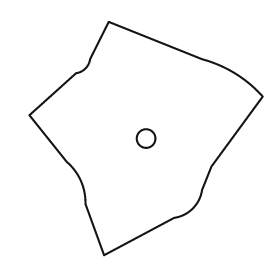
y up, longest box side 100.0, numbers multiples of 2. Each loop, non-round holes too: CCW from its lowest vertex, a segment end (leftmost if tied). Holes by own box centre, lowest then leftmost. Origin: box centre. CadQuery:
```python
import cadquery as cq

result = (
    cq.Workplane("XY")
    .moveTo(-18.0, -50.0)
    .lineTo(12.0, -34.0)
    .threePointArc((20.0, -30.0), (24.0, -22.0))
    .lineTo(28.0, -12.0)
    .lineTo(50.0, 18.0)
    .threePointArc((38.0, 28.0), (24.0, 34.0))
    .lineTo(-16.0, 50.0)
    .lineTo(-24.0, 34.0)
    .threePointArc((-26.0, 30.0), (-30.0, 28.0))
    .lineTo(-50.0, 10.0)
    .lineTo(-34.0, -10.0)
    .threePointArc((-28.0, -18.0), (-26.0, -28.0))
    .close()
    .moveTo(0.0, 0.0)
    .circle(4.0)
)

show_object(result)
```